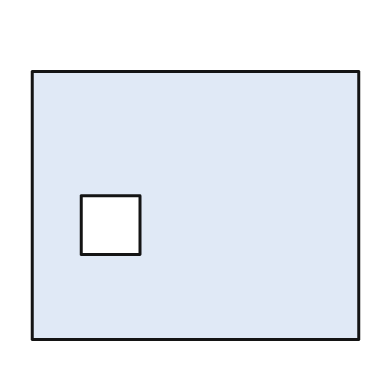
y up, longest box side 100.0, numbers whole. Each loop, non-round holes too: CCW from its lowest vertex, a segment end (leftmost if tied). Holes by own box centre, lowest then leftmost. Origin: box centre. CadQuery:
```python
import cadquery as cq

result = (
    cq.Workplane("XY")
    .moveTo(-50.0, -41.0)
    .lineTo(50.0, -41.0)
    .lineTo(50.0, 41.0)
    .lineTo(-50.0, 41.0)
    .close()
    .moveTo(-35.0, -15.0)
    .lineTo(-17.0, -15.0)
    .lineTo(-17.0, 3.0)
    .lineTo(-35.0, 3.0)
    .close()
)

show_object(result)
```